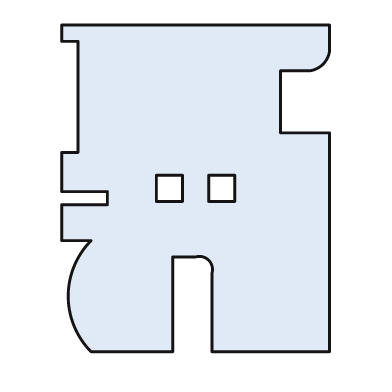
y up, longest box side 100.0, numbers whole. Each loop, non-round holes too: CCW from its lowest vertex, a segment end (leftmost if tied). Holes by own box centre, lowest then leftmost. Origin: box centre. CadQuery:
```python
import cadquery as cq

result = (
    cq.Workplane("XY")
    .moveTo(-32.0, -50.0)
    .lineTo(-7.0, -50.0)
    .lineTo(-7.0, -21.0)
    .lineTo(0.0, -21.0)
    .threePointArc((4.0, -22.0), (5.0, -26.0))
    .lineTo(5.0, -50.0)
    .lineTo(41.0, -50.0)
    .lineTo(41.0, 17.0)
    .lineTo(26.0, 17.0)
    .lineTo(26.0, 36.0)
    .lineTo(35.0, 36.0)
    .threePointArc((39.0, 38.0), (41.0, 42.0))
    .lineTo(41.0, 50.0)
    .lineTo(-41.0, 50.0)
    .lineTo(-41.0, 45.0)
    .lineTo(-36.0, 45.0)
    .lineTo(-36.0, 11.0)
    .lineTo(-41.0, 11.0)
    .lineTo(-41.0, -1.0)
    .lineTo(-27.0, -1.0)
    .lineTo(-27.0, -5.0)
    .lineTo(-41.0, -5.0)
    .lineTo(-41.0, -16.0)
    .lineTo(-32.0, -16.0)
    .threePointArc((-39.0, -33.0), (-32.0, -50.0))
    .close()
    .moveTo(-12.0, -4.0)
    .lineTo(-4.0, -4.0)
    .lineTo(-4.0, 4.0)
    .lineTo(-12.0, 4.0)
    .close()
    .moveTo(4.0, -4.0)
    .lineTo(12.0, -4.0)
    .lineTo(12.0, 4.0)
    .lineTo(4.0, 4.0)
    .close()
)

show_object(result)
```